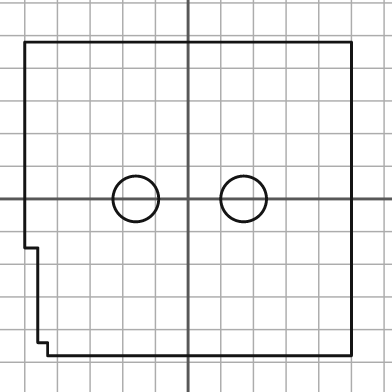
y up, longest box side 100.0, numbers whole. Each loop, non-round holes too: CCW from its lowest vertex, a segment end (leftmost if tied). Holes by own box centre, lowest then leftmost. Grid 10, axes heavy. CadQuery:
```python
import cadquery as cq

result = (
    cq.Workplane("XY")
    .moveTo(-43.0, -48.0)
    .lineTo(50.0, -48.0)
    .lineTo(50.0, 48.0)
    .lineTo(-50.0, 48.0)
    .lineTo(-50.0, -15.0)
    .lineTo(-46.0, -15.0)
    .lineTo(-46.0, -44.0)
    .lineTo(-43.0, -44.0)
    .close()
    .moveTo(-16.0, 0.0)
    .circle(7.0)
    .moveTo(17.0, 0.0)
    .circle(7.0)
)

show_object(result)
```